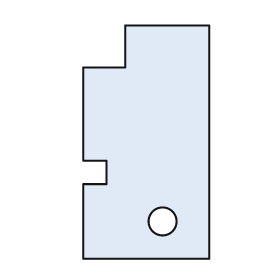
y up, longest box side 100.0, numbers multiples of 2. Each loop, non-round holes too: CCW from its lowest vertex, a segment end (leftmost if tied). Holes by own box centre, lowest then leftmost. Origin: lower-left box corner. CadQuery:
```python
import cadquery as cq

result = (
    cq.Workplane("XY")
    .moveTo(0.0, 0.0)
    .lineTo(54.0, 0.0)
    .lineTo(54.0, 100.0)
    .lineTo(18.0, 100.0)
    .lineTo(18.0, 82.0)
    .lineTo(0.0, 82.0)
    .lineTo(0.0, 42.0)
    .lineTo(10.0, 42.0)
    .lineTo(10.0, 32.0)
    .lineTo(0.0, 32.0)
    .close()
    .moveTo(34.0, 16.0)
    .circle(6.0)
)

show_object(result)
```